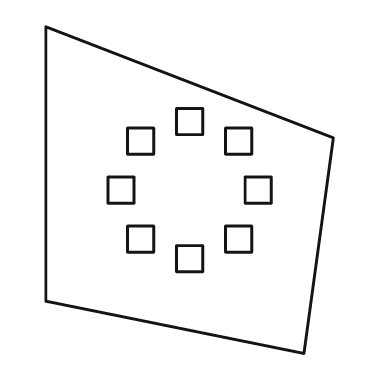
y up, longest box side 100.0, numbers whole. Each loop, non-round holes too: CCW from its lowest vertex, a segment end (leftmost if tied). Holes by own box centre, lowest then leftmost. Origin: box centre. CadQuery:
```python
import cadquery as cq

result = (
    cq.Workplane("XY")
    .moveTo(35.0, -50.0)
    .lineTo(44.0, 16.0)
    .lineTo(-44.0, 50.0)
    .lineTo(-44.0, -34.0)
    .close()
    .moveTo(-4.0, -25.0)
    .lineTo(4.0, -25.0)
    .lineTo(4.0, -17.0)
    .lineTo(-4.0, -17.0)
    .close()
    .moveTo(-19.0, -19.0)
    .lineTo(-11.0, -19.0)
    .lineTo(-11.0, -11.0)
    .lineTo(-19.0, -11.0)
    .close()
    .moveTo(11.0, -19.0)
    .lineTo(19.0, -19.0)
    .lineTo(19.0, -11.0)
    .lineTo(11.0, -11.0)
    .close()
    .moveTo(-25.0, -4.0)
    .lineTo(-17.0, -4.0)
    .lineTo(-17.0, 4.0)
    .lineTo(-25.0, 4.0)
    .close()
    .moveTo(17.0, -4.0)
    .lineTo(25.0, -4.0)
    .lineTo(25.0, 4.0)
    .lineTo(17.0, 4.0)
    .close()
    .moveTo(-19.0, 11.0)
    .lineTo(-11.0, 11.0)
    .lineTo(-11.0, 19.0)
    .lineTo(-19.0, 19.0)
    .close()
    .moveTo(11.0, 11.0)
    .lineTo(19.0, 11.0)
    .lineTo(19.0, 19.0)
    .lineTo(11.0, 19.0)
    .close()
    .moveTo(-4.0, 17.0)
    .lineTo(4.0, 17.0)
    .lineTo(4.0, 25.0)
    .lineTo(-4.0, 25.0)
    .close()
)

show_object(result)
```